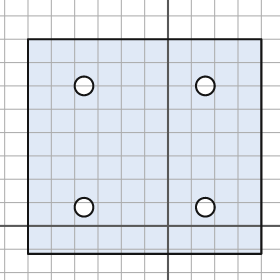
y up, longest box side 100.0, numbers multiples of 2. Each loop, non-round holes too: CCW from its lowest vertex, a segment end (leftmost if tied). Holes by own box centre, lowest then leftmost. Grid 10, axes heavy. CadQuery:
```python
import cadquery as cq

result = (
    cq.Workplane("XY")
    .moveTo(-60.0, -12.0)
    .lineTo(40.0, -12.0)
    .lineTo(40.0, 80.0)
    .lineTo(-60.0, 80.0)
    .close()
    .moveTo(-36.0, 8.0)
    .circle(4.0)
    .moveTo(16.0, 8.0)
    .circle(4.0)
    .moveTo(-36.0, 60.0)
    .circle(4.0)
    .moveTo(16.0, 60.0)
    .circle(4.0)
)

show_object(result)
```